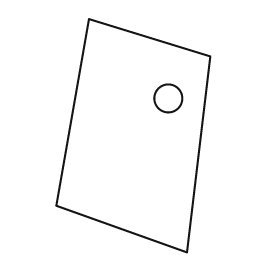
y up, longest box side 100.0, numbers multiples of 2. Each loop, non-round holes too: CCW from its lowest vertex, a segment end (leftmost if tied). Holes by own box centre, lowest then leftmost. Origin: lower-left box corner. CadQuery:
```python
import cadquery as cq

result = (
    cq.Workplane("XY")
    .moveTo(56.0, 0.0)
    .lineTo(66.0, 84.0)
    .lineTo(14.0, 100.0)
    .lineTo(0.0, 20.0)
    .close()
    .moveTo(48.0, 66.0)
    .circle(6.0)
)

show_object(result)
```